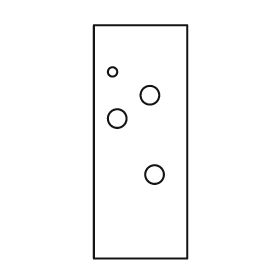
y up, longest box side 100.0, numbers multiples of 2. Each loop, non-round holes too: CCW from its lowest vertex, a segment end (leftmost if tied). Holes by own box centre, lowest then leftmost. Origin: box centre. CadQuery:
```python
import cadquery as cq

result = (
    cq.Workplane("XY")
    .moveTo(-20.0, -50.0)
    .lineTo(20.0, -50.0)
    .lineTo(20.0, 50.0)
    .lineTo(-20.0, 50.0)
    .close()
    .moveTo(6.0, -14.0)
    .circle(4.0)
    .moveTo(-10.0, 10.0)
    .circle(4.0)
    .moveTo(4.0, 20.0)
    .circle(4.0)
    .moveTo(-12.0, 30.0)
    .circle(2.0)
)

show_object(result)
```